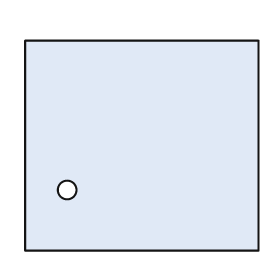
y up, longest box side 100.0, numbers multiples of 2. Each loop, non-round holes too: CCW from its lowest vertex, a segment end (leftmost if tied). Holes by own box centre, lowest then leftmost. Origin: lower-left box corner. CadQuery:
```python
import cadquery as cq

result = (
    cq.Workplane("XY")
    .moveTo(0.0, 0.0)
    .lineTo(100.0, 0.0)
    .lineTo(100.0, 90.0)
    .lineTo(0.0, 90.0)
    .close()
    .moveTo(18.0, 26.0)
    .circle(4.0)
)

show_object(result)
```